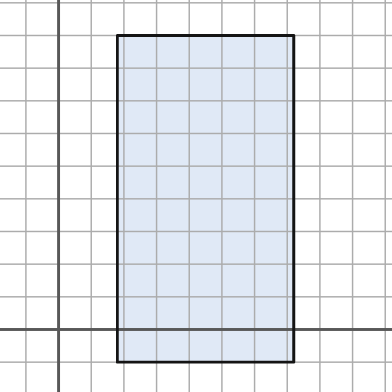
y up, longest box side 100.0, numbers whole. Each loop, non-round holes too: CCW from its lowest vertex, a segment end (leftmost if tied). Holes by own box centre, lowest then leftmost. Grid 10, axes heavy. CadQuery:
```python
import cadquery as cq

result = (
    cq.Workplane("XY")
    .moveTo(18.0, -10.0)
    .lineTo(72.0, -10.0)
    .lineTo(72.0, 90.0)
    .lineTo(18.0, 90.0)
    .close()
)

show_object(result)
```